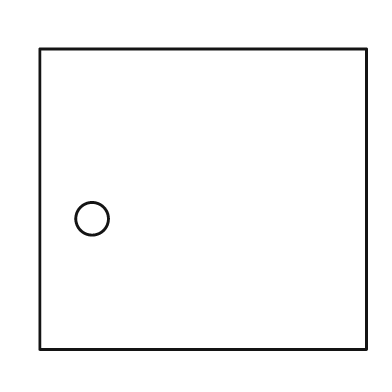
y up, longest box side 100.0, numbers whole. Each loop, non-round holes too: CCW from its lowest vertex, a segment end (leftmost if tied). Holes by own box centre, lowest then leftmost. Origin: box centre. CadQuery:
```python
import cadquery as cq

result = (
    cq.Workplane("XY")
    .moveTo(-50.0, -46.0)
    .lineTo(50.0, -46.0)
    .lineTo(50.0, 46.0)
    .lineTo(-50.0, 46.0)
    .close()
    .moveTo(-34.0, -6.0)
    .circle(5.0)
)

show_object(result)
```